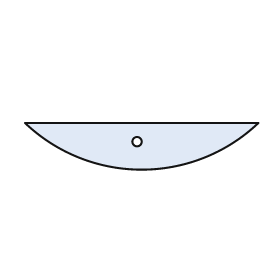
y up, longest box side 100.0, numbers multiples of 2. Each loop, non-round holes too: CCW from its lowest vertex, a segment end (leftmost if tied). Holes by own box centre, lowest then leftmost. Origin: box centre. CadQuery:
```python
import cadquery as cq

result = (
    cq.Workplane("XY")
    .moveTo(-50.0, 10.0)
    .threePointArc((0.0, -10.0), (50.0, 10.0))
    .close()
    .moveTo(-2.0, 2.0)
    .circle(2.0)
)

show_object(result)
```